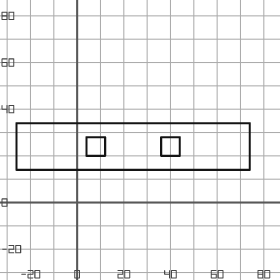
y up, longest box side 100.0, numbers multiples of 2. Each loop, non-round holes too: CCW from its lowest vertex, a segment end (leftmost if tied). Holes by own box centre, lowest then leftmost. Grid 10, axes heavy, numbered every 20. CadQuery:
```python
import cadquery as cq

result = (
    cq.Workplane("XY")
    .moveTo(-26.0, 14.0)
    .lineTo(74.0, 14.0)
    .lineTo(74.0, 34.0)
    .lineTo(-26.0, 34.0)
    .close()
    .moveTo(4.0, 20.0)
    .lineTo(12.0, 20.0)
    .lineTo(12.0, 28.0)
    .lineTo(4.0, 28.0)
    .close()
    .moveTo(36.0, 20.0)
    .lineTo(44.0, 20.0)
    .lineTo(44.0, 28.0)
    .lineTo(36.0, 28.0)
    .close()
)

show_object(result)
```